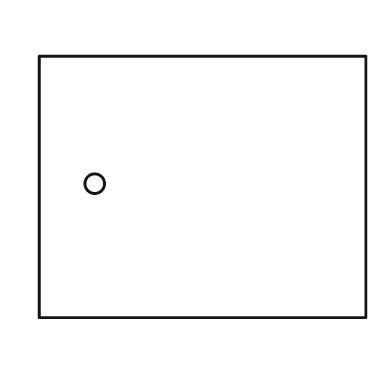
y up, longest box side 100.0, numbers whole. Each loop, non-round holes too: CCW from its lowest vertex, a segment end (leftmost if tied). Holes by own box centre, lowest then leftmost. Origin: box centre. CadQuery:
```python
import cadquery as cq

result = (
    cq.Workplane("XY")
    .moveTo(-50.0, -40.0)
    .lineTo(50.0, -40.0)
    .lineTo(50.0, 40.0)
    .lineTo(-50.0, 40.0)
    .close()
    .moveTo(-33.0, 1.0)
    .circle(3.0)
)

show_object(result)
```